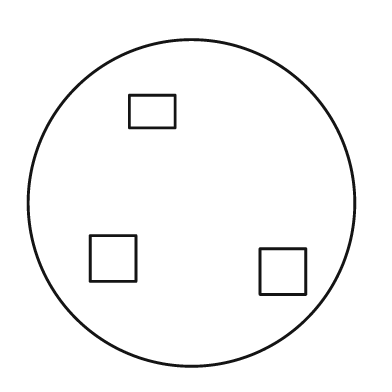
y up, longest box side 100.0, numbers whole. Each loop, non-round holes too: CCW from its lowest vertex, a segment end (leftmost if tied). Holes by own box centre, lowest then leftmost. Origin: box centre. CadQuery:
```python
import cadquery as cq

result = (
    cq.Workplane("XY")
    .moveTo(0.0, 0.0)
    .circle(50.0)
    .moveTo(21.0, -28.0)
    .lineTo(35.0, -28.0)
    .lineTo(35.0, -14.0)
    .lineTo(21.0, -14.0)
    .close()
    .moveTo(-31.0, -24.0)
    .lineTo(-17.0, -24.0)
    .lineTo(-17.0, -10.0)
    .lineTo(-31.0, -10.0)
    .close()
    .moveTo(-19.0, 23.0)
    .lineTo(-5.0, 23.0)
    .lineTo(-5.0, 33.0)
    .lineTo(-19.0, 33.0)
    .close()
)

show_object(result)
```